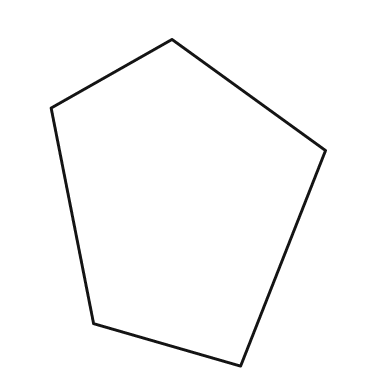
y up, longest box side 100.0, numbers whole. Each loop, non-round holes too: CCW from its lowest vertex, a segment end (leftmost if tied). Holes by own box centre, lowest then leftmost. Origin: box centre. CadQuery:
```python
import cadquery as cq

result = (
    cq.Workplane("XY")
    .moveTo(16.0, -50.0)
    .lineTo(42.0, 16.0)
    .lineTo(-5.0, 50.0)
    .lineTo(-42.0, 29.0)
    .lineTo(-29.0, -37.0)
    .close()
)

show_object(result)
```